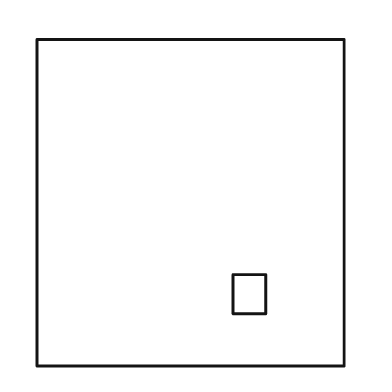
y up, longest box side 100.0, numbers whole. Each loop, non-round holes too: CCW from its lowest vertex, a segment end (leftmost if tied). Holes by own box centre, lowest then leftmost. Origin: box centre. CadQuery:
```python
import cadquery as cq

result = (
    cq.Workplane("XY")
    .moveTo(-47.0, -50.0)
    .lineTo(47.0, -50.0)
    .lineTo(47.0, 50.0)
    .lineTo(-47.0, 50.0)
    .close()
    .moveTo(13.0, -34.0)
    .lineTo(23.0, -34.0)
    .lineTo(23.0, -22.0)
    .lineTo(13.0, -22.0)
    .close()
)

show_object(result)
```